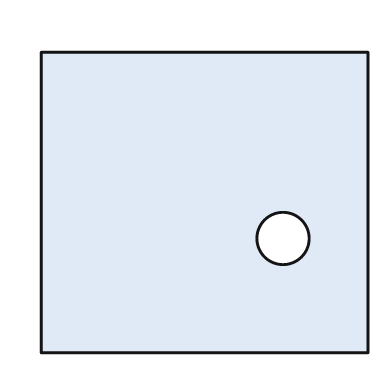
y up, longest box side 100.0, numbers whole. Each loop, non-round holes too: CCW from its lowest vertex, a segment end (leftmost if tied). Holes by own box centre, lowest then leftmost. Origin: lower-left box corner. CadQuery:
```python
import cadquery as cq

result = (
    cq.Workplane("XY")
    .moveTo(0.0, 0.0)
    .lineTo(100.0, 0.0)
    .lineTo(100.0, 92.0)
    .lineTo(0.0, 92.0)
    .close()
    .moveTo(74.0, 35.0)
    .circle(8.0)
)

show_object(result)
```